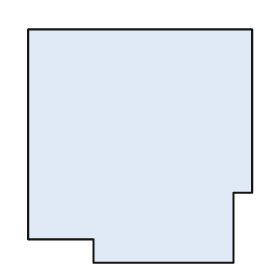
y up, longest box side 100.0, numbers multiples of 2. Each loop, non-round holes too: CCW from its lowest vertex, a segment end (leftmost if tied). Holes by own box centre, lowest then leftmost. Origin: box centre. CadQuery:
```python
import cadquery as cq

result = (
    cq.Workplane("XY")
    .moveTo(-20.0, -50.0)
    .lineTo(40.0, -50.0)
    .lineTo(40.0, -20.0)
    .lineTo(48.0, -20.0)
    .lineTo(48.0, 50.0)
    .lineTo(-48.0, 50.0)
    .lineTo(-48.0, -40.0)
    .lineTo(-20.0, -40.0)
    .close()
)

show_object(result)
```